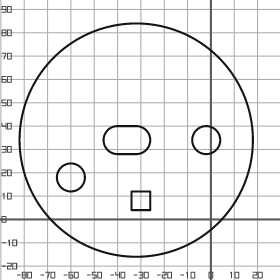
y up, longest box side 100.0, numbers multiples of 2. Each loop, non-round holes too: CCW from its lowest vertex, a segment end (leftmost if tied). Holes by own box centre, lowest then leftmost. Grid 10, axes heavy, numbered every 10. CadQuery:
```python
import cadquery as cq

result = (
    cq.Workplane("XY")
    .moveTo(-32.0, 34.0)
    .circle(50.0)
    .moveTo(-34.0, 4.0)
    .lineTo(-26.0, 4.0)
    .lineTo(-26.0, 12.0)
    .lineTo(-34.0, 12.0)
    .close()
    .moveTo(-60.0, 18.0)
    .circle(6.0)
    .moveTo(-40.0, 28.0)
    .lineTo(-32.0, 28.0)
    .threePointArc((-26.0, 34.0), (-32.0, 40.0))
    .lineTo(-40.0, 40.0)
    .threePointArc((-46.0, 34.0), (-40.0, 28.0))
    .close()
    .moveTo(-2.0, 34.0)
    .circle(6.0)
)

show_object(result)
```